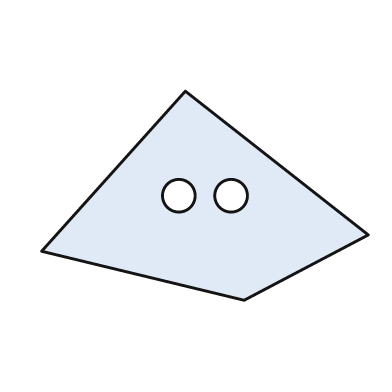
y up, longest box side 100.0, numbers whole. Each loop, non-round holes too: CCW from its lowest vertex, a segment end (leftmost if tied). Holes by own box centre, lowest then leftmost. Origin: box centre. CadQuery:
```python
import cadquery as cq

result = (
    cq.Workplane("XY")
    .moveTo(12.0, -32.0)
    .lineTo(50.0, -12.0)
    .lineTo(-6.0, 32.0)
    .lineTo(-50.0, -17.0)
    .close()
    .moveTo(-8.0, 0.0)
    .circle(5.0)
    .moveTo(8.0, 0.0)
    .circle(5.0)
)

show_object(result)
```